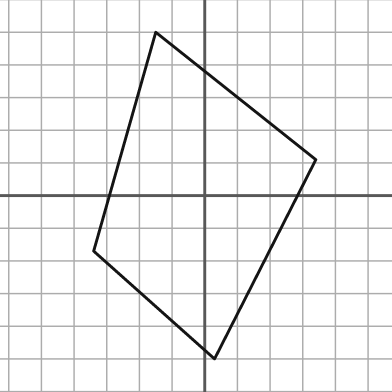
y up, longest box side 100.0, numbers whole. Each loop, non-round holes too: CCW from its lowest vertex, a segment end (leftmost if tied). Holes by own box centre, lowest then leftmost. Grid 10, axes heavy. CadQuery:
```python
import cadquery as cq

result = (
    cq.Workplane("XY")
    .moveTo(3.0, -50.0)
    .lineTo(34.0, 11.0)
    .lineTo(-15.0, 50.0)
    .lineTo(-34.0, -17.0)
    .close()
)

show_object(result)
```